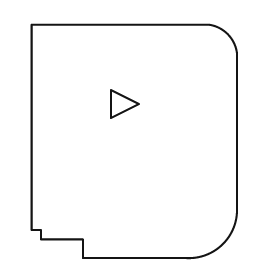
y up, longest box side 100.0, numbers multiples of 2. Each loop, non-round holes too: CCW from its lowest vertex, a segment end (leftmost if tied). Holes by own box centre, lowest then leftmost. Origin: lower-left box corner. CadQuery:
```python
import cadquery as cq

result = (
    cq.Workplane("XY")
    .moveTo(22.0, 0.0)
    .lineTo(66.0, 0.0)
    .threePointArc((82.0, 6.0), (88.0, 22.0))
    .lineTo(88.0, 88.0)
    .threePointArc((84.0, 96.0), (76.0, 100.0))
    .lineTo(0.0, 100.0)
    .lineTo(0.0, 12.0)
    .lineTo(4.0, 12.0)
    .lineTo(4.0, 8.0)
    .lineTo(22.0, 8.0)
    .close()
    .moveTo(34.0, 60.0)
    .lineTo(46.0, 66.0)
    .lineTo(34.0, 72.0)
    .close()
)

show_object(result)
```